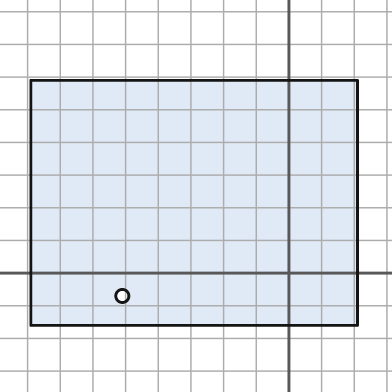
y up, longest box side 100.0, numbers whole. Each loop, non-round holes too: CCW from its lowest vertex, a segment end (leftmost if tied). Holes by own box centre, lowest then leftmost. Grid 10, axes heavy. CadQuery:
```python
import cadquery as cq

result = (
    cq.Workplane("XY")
    .moveTo(-79.0, -16.0)
    .lineTo(21.0, -16.0)
    .lineTo(21.0, 59.0)
    .lineTo(-79.0, 59.0)
    .close()
    .moveTo(-51.0, -7.0)
    .circle(2.0)
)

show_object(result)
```